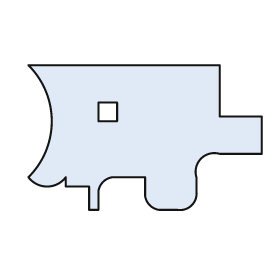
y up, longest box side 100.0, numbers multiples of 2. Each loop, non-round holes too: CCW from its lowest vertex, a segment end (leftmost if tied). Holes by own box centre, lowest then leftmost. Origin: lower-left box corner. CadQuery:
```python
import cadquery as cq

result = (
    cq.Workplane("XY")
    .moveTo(26.0, 0.0)
    .lineTo(30.0, 0.0)
    .lineTo(30.0, 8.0)
    .threePointArc((32.0, 12.0), (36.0, 14.0))
    .lineTo(50.0, 14.0)
    .lineTo(50.0, 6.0)
    .threePointArc((52.0, 2.0), (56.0, 0.0))
    .lineTo(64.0, 0.0)
    .threePointArc((70.0, 2.0), (72.0, 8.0))
    .lineTo(72.0, 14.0)
    .threePointArc((74.0, 22.0), (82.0, 24.0))
    .lineTo(100.0, 24.0)
    .lineTo(100.0, 40.0)
    .lineTo(82.0, 40.0)
    .lineTo(82.0, 62.0)
    .lineTo(0.0, 62.0)
    .threePointArc((10.0, 38.0), (0.0, 14.0))
    .threePointArc((8.0, 10.0), (16.0, 14.0))
    .lineTo(16.0, 10.0)
    .lineTo(26.0, 10.0)
    .close()
    .moveTo(30.0, 38.0)
    .lineTo(38.0, 38.0)
    .lineTo(38.0, 46.0)
    .lineTo(30.0, 46.0)
    .close()
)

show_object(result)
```